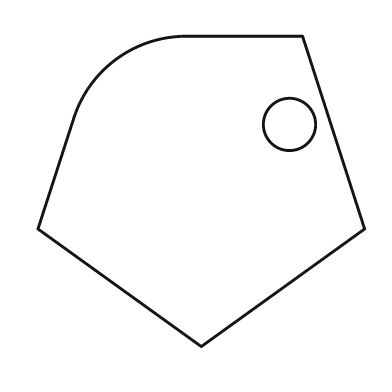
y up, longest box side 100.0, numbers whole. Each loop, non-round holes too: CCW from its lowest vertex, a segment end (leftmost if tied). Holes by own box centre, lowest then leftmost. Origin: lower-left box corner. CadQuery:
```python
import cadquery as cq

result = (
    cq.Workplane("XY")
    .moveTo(50.0, 0.0)
    .lineTo(100.0, 36.0)
    .lineTo(81.0, 95.0)
    .lineTo(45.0, 95.0)
    .threePointArc((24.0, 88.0), (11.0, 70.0))
    .lineTo(0.0, 36.0)
    .close()
    .moveTo(77.0, 68.0)
    .circle(8.0)
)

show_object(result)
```